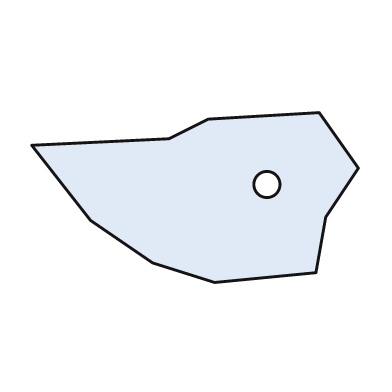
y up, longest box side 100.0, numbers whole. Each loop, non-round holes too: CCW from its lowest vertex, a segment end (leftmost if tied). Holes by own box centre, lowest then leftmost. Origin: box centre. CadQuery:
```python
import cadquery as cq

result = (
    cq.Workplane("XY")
    .moveTo(6.0, -26.0)
    .lineTo(37.0, -23.0)
    .lineTo(40.0, -6.0)
    .lineTo(50.0, 9.0)
    .lineTo(38.0, 26.0)
    .lineTo(4.0, 24.0)
    .lineTo(-8.0, 18.0)
    .lineTo(-50.0, 16.0)
    .lineTo(-32.0, -7.0)
    .lineTo(-13.0, -20.0)
    .close()
    .moveTo(22.0, 4.0)
    .circle(4.0)
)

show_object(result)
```